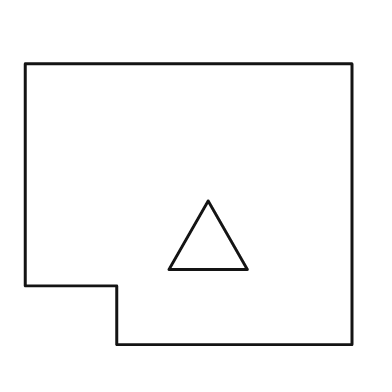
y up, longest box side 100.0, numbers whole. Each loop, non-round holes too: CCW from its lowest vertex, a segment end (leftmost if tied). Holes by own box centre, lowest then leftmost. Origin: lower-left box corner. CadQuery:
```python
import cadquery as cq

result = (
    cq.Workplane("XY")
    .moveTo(28.0, 0.0)
    .lineTo(100.0, 0.0)
    .lineTo(100.0, 86.0)
    .lineTo(0.0, 86.0)
    .lineTo(0.0, 18.0)
    .lineTo(28.0, 18.0)
    .close()
    .moveTo(44.0, 23.0)
    .lineTo(68.0, 23.0)
    .lineTo(56.0, 44.0)
    .close()
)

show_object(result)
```